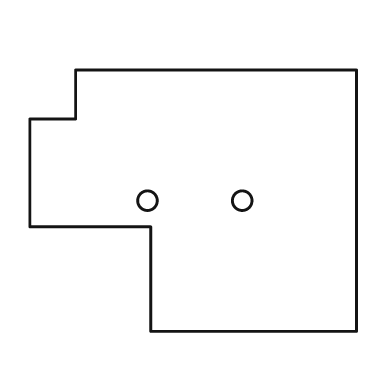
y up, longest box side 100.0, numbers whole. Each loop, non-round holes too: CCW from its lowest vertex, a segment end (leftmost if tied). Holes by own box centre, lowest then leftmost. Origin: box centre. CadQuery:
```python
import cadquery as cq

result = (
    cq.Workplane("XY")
    .moveTo(-13.0, -40.0)
    .lineTo(50.0, -40.0)
    .lineTo(50.0, 40.0)
    .lineTo(-36.0, 40.0)
    .lineTo(-36.0, 25.0)
    .lineTo(-50.0, 25.0)
    .lineTo(-50.0, -8.0)
    .lineTo(-13.0, -8.0)
    .close()
    .moveTo(-14.0, 0.0)
    .circle(3.0)
    .moveTo(15.0, 0.0)
    .circle(3.0)
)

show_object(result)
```